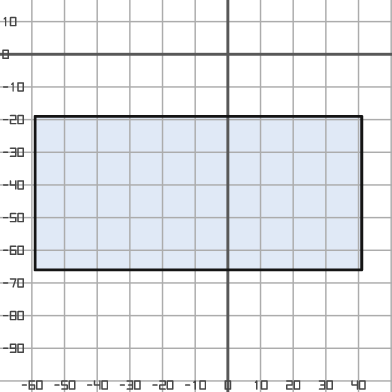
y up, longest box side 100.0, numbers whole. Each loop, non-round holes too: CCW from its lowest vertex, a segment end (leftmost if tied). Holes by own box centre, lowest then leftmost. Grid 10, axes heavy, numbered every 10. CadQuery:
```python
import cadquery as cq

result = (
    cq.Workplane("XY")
    .moveTo(-59.0, -66.0)
    .lineTo(41.0, -66.0)
    .lineTo(41.0, -19.0)
    .lineTo(-59.0, -19.0)
    .close()
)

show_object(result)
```